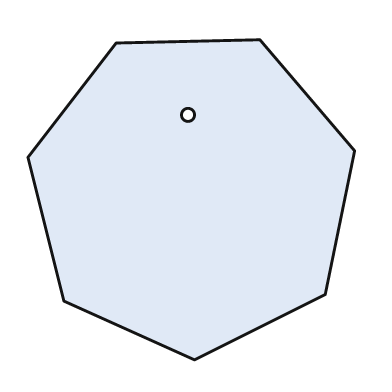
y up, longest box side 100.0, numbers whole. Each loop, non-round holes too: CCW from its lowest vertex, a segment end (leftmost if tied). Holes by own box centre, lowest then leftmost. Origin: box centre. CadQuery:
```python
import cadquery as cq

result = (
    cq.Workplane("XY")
    .moveTo(1.0, -49.0)
    .lineTo(41.0, -29.0)
    .lineTo(50.0, 15.0)
    .lineTo(21.0, 49.0)
    .lineTo(-23.0, 48.0)
    .lineTo(-50.0, 13.0)
    .lineTo(-39.0, -31.0)
    .close()
    .moveTo(-1.0, 26.0)
    .circle(2.0)
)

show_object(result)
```